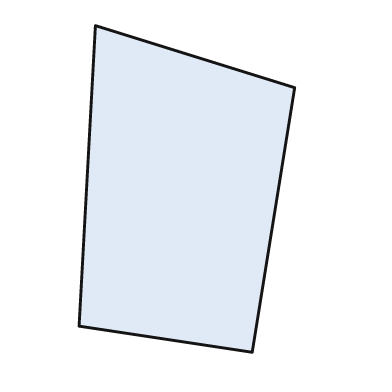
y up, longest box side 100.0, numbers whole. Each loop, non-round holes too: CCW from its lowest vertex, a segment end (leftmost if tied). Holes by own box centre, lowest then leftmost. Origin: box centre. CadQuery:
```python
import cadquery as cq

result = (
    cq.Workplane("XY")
    .moveTo(20.0, -50.0)
    .lineTo(33.0, 31.0)
    .lineTo(-28.0, 50.0)
    .lineTo(-33.0, -42.0)
    .close()
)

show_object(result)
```